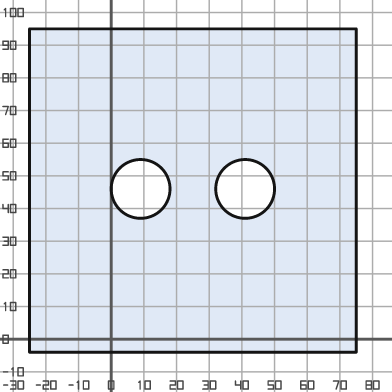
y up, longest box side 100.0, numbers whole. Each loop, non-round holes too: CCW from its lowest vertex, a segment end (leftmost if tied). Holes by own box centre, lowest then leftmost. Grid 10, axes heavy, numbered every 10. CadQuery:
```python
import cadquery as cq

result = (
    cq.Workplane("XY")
    .moveTo(-25.0, -4.0)
    .lineTo(75.0, -4.0)
    .lineTo(75.0, 95.0)
    .lineTo(-25.0, 95.0)
    .close()
    .moveTo(9.0, 46.0)
    .circle(9.0)
    .moveTo(41.0, 46.0)
    .circle(9.0)
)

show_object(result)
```